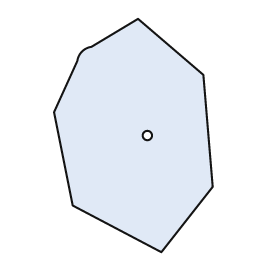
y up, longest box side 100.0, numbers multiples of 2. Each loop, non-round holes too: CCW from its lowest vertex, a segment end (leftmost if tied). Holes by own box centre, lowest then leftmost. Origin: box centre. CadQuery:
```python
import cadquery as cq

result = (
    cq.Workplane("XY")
    .moveTo(12.0, -50.0)
    .lineTo(34.0, -22.0)
    .lineTo(30.0, 26.0)
    .lineTo(2.0, 50.0)
    .lineTo(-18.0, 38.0)
    .threePointArc((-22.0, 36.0), (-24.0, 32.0))
    .lineTo(-34.0, 10.0)
    .lineTo(-26.0, -30.0)
    .close()
    .moveTo(6.0, 0.0)
    .circle(2.0)
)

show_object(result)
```